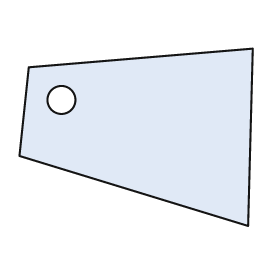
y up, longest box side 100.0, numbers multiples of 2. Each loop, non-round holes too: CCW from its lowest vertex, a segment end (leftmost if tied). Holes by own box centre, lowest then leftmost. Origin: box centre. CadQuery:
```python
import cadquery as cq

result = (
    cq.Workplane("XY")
    .moveTo(48.0, -38.0)
    .lineTo(50.0, 38.0)
    .lineTo(-46.0, 30.0)
    .lineTo(-50.0, -8.0)
    .close()
    .moveTo(-32.0, 16.0)
    .circle(6.0)
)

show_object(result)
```